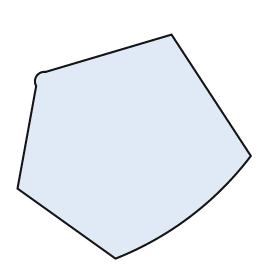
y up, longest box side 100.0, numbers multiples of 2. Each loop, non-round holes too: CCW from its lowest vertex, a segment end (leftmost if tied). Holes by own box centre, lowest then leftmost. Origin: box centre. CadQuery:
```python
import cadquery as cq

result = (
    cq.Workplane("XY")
    .moveTo(-8.0, -48.0)
    .threePointArc((24.0, -30.0), (50.0, -4.0))
    .lineTo(16.0, 48.0)
    .lineTo(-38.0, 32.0)
    .threePointArc((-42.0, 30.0), (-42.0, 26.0))
    .lineTo(-50.0, -18.0)
    .close()
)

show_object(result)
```